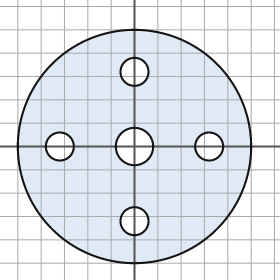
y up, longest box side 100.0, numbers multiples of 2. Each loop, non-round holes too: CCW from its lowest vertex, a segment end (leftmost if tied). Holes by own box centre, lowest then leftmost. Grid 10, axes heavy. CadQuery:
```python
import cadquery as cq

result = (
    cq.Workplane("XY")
    .moveTo(0.0, 0.0)
    .circle(50.0)
    .moveTo(0.0, -32.0)
    .circle(6.0)
    .moveTo(-32.0, 0.0)
    .circle(6.0)
    .moveTo(0.0, 0.0)
    .circle(8.0)
    .moveTo(32.0, 0.0)
    .circle(6.0)
    .moveTo(0.0, 32.0)
    .circle(6.0)
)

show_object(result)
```